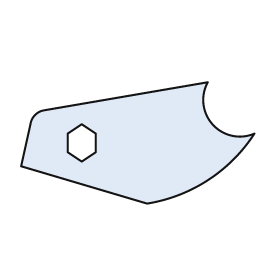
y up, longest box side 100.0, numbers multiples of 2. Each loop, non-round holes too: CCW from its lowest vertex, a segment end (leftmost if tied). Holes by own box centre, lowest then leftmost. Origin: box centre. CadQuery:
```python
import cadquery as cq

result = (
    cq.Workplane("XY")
    .moveTo(4.0, -26.0)
    .threePointArc((30.0, -16.0), (50.0, 4.0))
    .threePointArc((32.0, 8.0), (30.0, 26.0))
    .lineTo(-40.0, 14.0)
    .threePointArc((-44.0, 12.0), (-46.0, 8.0))
    .lineTo(-50.0, -10.0)
    .close()
    .moveTo(-24.0, -8.0)
    .lineTo(-18.0, -4.0)
    .lineTo(-18.0, 4.0)
    .lineTo(-24.0, 8.0)
    .lineTo(-30.0, 4.0)
    .lineTo(-30.0, -4.0)
    .close()
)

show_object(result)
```